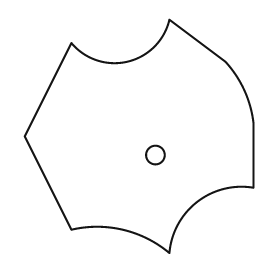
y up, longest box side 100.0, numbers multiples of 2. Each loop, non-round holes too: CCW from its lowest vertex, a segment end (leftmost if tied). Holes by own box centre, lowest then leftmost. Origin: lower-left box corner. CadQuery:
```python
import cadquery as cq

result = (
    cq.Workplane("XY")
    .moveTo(62.0, 0.0)
    .threePointArc((74.0, 22.0), (98.0, 28.0))
    .lineTo(98.0, 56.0)
    .threePointArc((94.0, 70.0), (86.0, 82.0))
    .lineTo(62.0, 100.0)
    .threePointArc((44.0, 82.0), (20.0, 90.0))
    .lineTo(0.0, 50.0)
    .lineTo(20.0, 10.0)
    .threePointArc((42.0, 10.0), (62.0, 0.0))
    .close()
    .moveTo(56.0, 42.0)
    .circle(4.0)
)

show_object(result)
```